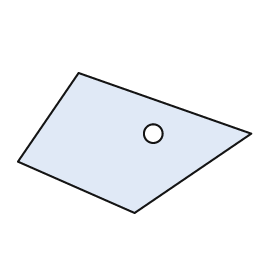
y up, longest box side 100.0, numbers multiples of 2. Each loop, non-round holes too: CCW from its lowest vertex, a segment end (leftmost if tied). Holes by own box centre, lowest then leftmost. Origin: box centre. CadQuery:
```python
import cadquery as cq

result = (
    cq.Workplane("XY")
    .moveTo(0.0, -30.0)
    .lineTo(50.0, 4.0)
    .lineTo(-24.0, 30.0)
    .lineTo(-50.0, -8.0)
    .close()
    .moveTo(8.0, 4.0)
    .circle(4.0)
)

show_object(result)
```